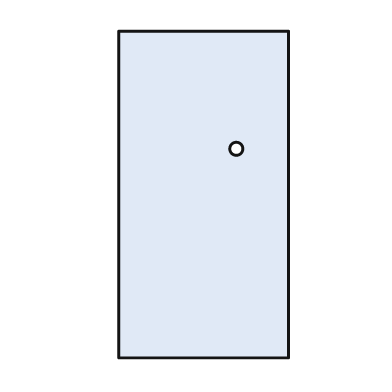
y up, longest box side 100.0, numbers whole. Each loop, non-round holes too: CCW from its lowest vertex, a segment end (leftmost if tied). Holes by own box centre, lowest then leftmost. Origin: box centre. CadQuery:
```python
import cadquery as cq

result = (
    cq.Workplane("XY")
    .moveTo(-26.0, -50.0)
    .lineTo(26.0, -50.0)
    .lineTo(26.0, 50.0)
    .lineTo(-26.0, 50.0)
    .close()
    .moveTo(10.0, 14.0)
    .circle(2.0)
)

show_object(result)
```